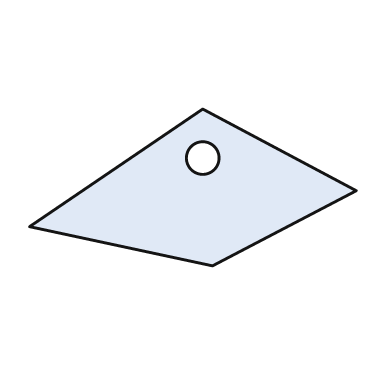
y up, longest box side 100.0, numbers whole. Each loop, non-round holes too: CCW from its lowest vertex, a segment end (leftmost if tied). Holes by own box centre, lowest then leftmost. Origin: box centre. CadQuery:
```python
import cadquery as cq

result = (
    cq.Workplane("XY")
    .moveTo(6.0, -24.0)
    .lineTo(50.0, -1.0)
    .lineTo(3.0, 24.0)
    .lineTo(-50.0, -12.0)
    .close()
    .moveTo(3.0, 9.0)
    .circle(5.0)
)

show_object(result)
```